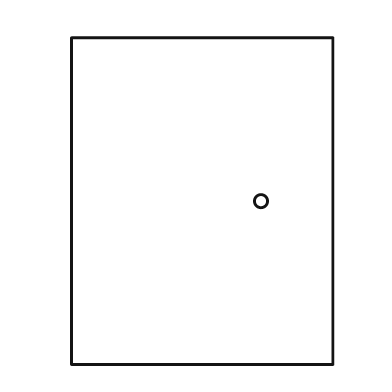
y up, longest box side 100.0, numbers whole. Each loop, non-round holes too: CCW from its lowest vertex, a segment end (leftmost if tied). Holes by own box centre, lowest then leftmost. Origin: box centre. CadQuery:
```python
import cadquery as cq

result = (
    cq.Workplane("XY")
    .moveTo(-40.0, -50.0)
    .lineTo(40.0, -50.0)
    .lineTo(40.0, 50.0)
    .lineTo(-40.0, 50.0)
    .close()
    .moveTo(18.0, 0.0)
    .circle(2.0)
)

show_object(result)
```